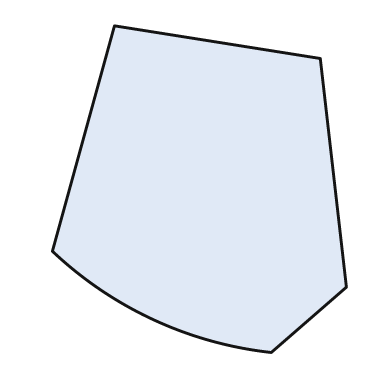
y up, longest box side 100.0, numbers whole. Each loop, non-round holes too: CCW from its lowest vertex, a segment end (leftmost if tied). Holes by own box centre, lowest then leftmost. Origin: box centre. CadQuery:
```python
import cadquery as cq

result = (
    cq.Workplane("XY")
    .moveTo(22.0, -50.0)
    .lineTo(45.0, -30.0)
    .lineTo(37.0, 40.0)
    .lineTo(-26.0, 50.0)
    .lineTo(-45.0, -19.0)
    .threePointArc((-14.0, -40.0), (22.0, -50.0))
    .close()
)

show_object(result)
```